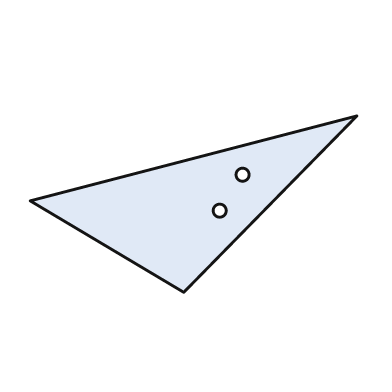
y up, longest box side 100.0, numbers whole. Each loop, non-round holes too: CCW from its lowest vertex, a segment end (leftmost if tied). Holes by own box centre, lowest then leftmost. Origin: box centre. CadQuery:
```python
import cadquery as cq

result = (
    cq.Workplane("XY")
    .moveTo(-3.0, -27.0)
    .lineTo(50.0, 27.0)
    .lineTo(-50.0, 1.0)
    .close()
    .moveTo(8.0, -2.0)
    .circle(2.0)
    .moveTo(15.0, 9.0)
    .circle(2.0)
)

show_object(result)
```